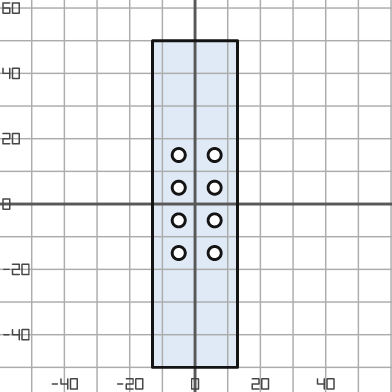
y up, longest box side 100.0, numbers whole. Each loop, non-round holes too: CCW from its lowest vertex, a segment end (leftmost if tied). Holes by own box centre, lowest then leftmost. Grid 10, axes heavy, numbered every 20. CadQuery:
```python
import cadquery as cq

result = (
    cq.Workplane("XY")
    .moveTo(-13.0, -50.0)
    .lineTo(13.0, -50.0)
    .lineTo(13.0, 50.0)
    .lineTo(-13.0, 50.0)
    .close()
    .moveTo(-5.0, -15.0)
    .circle(2.0)
    .moveTo(6.0, -15.0)
    .circle(2.0)
    .moveTo(-5.0, -5.0)
    .circle(2.0)
    .moveTo(6.0, -5.0)
    .circle(2.0)
    .moveTo(-5.0, 5.0)
    .circle(2.0)
    .moveTo(6.0, 5.0)
    .circle(2.0)
    .moveTo(-5.0, 15.0)
    .circle(2.0)
    .moveTo(6.0, 15.0)
    .circle(2.0)
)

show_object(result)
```